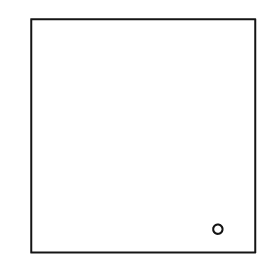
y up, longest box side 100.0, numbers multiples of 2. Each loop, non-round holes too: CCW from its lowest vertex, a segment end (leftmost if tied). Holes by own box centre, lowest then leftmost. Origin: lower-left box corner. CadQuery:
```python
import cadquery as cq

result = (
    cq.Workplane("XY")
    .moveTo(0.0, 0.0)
    .lineTo(96.0, 0.0)
    .lineTo(96.0, 100.0)
    .lineTo(0.0, 100.0)
    .close()
    .moveTo(80.0, 10.0)
    .circle(2.0)
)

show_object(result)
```